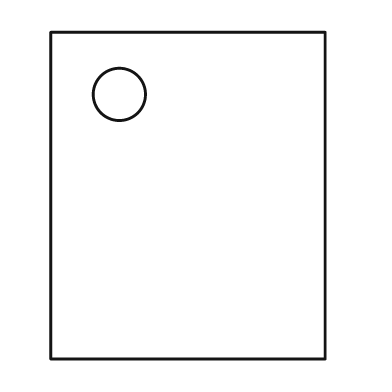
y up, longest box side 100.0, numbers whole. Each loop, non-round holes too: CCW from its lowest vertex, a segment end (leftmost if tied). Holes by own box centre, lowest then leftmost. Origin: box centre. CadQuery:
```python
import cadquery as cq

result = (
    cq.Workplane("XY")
    .moveTo(-42.0, -50.0)
    .lineTo(42.0, -50.0)
    .lineTo(42.0, 50.0)
    .lineTo(-42.0, 50.0)
    .close()
    .moveTo(-21.0, 31.0)
    .circle(8.0)
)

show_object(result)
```